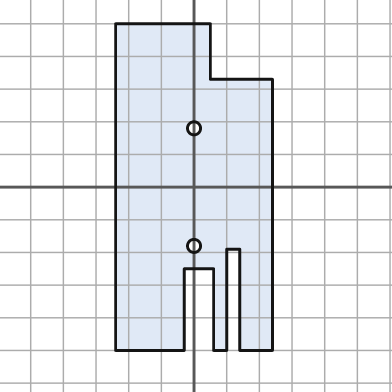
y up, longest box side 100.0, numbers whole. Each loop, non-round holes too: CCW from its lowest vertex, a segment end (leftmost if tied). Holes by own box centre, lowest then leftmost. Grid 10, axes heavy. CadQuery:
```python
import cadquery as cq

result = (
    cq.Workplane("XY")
    .moveTo(-24.0, -50.0)
    .lineTo(-3.0, -50.0)
    .lineTo(-3.0, -25.0)
    .lineTo(6.0, -25.0)
    .lineTo(6.0, -50.0)
    .lineTo(10.0, -50.0)
    .lineTo(10.0, -19.0)
    .lineTo(14.0, -19.0)
    .lineTo(14.0, -50.0)
    .lineTo(24.0, -50.0)
    .lineTo(24.0, 33.0)
    .lineTo(5.0, 33.0)
    .lineTo(5.0, 50.0)
    .lineTo(-24.0, 50.0)
    .close()
    .moveTo(0.0, -18.0)
    .circle(2.0)
    .moveTo(0.0, 18.0)
    .circle(2.0)
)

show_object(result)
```